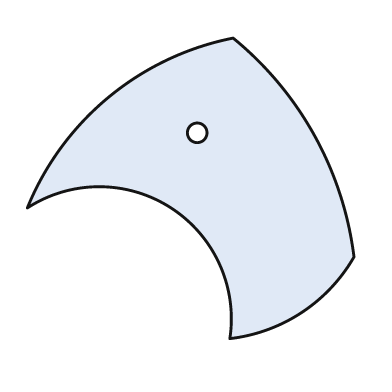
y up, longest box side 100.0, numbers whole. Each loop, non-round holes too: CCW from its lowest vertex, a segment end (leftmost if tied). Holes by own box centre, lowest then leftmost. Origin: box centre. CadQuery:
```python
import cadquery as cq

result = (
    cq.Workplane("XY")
    .moveTo(12.0, -46.0)
    .threePointArc((34.0, -38.0), (50.0, -21.0))
    .threePointArc((38.0, 16.0), (13.0, 46.0))
    .threePointArc((-25.0, 28.0), (-50.0, -6.0))
    .threePointArc((-6.0, -6.0), (12.0, -46.0))
    .close()
    .moveTo(2.0, 17.0)
    .circle(3.0)
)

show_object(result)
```